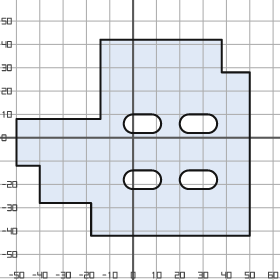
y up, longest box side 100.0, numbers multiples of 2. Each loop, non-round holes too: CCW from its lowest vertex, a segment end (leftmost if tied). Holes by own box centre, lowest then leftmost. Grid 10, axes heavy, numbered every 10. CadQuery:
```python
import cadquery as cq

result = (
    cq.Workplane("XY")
    .moveTo(-18.0, -42.0)
    .lineTo(50.0, -42.0)
    .lineTo(50.0, 28.0)
    .lineTo(38.0, 28.0)
    .lineTo(38.0, 42.0)
    .lineTo(-14.0, 42.0)
    .lineTo(-14.0, 8.0)
    .lineTo(-50.0, 8.0)
    .lineTo(-50.0, -12.0)
    .lineTo(-40.0, -12.0)
    .lineTo(-40.0, -28.0)
    .lineTo(-18.0, -28.0)
    .close()
    .moveTo(0.0, -22.0)
    .lineTo(8.0, -22.0)
    .threePointArc((12.0, -18.0), (8.0, -14.0))
    .lineTo(0.0, -14.0)
    .threePointArc((-4.0, -18.0), (0.0, -22.0))
    .close()
    .moveTo(24.0, -22.0)
    .lineTo(32.0, -22.0)
    .threePointArc((36.0, -18.0), (32.0, -14.0))
    .lineTo(24.0, -14.0)
    .threePointArc((20.0, -18.0), (24.0, -22.0))
    .close()
    .moveTo(0.0, 2.0)
    .lineTo(8.0, 2.0)
    .threePointArc((12.0, 6.0), (8.0, 10.0))
    .lineTo(0.0, 10.0)
    .threePointArc((-4.0, 6.0), (0.0, 2.0))
    .close()
    .moveTo(24.0, 2.0)
    .lineTo(32.0, 2.0)
    .threePointArc((36.0, 6.0), (32.0, 10.0))
    .lineTo(24.0, 10.0)
    .threePointArc((20.0, 6.0), (24.0, 2.0))
    .close()
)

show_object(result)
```